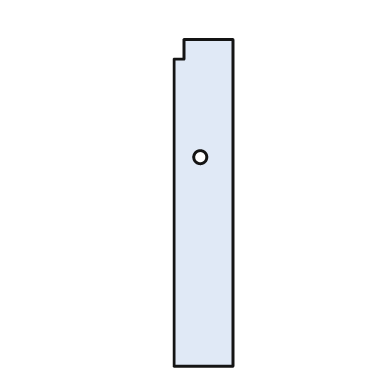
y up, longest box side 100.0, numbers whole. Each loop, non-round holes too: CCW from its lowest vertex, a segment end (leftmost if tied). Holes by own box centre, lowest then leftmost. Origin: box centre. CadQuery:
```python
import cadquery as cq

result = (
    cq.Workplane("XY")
    .moveTo(-9.0, -50.0)
    .lineTo(9.0, -50.0)
    .lineTo(9.0, 50.0)
    .lineTo(-6.0, 50.0)
    .lineTo(-6.0, 44.0)
    .lineTo(-9.0, 44.0)
    .close()
    .moveTo(-1.0, 14.0)
    .circle(2.0)
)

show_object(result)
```